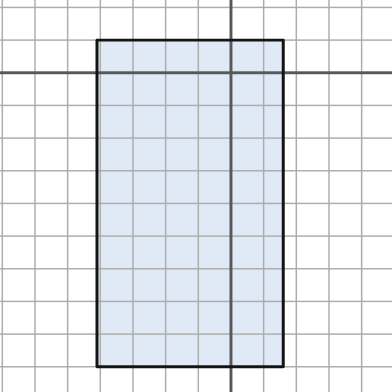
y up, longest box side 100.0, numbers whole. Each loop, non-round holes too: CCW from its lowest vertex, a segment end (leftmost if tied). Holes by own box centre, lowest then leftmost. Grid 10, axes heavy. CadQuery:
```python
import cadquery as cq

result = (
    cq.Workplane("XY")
    .moveTo(-41.0, -90.0)
    .lineTo(16.0, -90.0)
    .lineTo(16.0, 10.0)
    .lineTo(-41.0, 10.0)
    .close()
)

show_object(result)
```